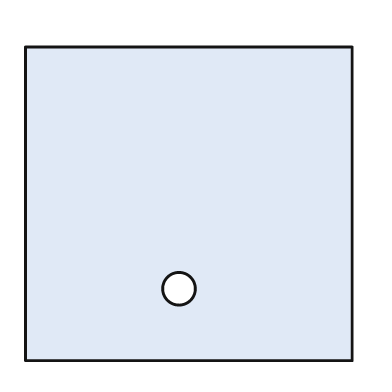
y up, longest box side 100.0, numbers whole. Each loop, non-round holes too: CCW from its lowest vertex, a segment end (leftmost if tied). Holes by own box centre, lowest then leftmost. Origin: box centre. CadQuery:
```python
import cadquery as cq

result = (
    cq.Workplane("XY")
    .moveTo(-50.0, -48.0)
    .lineTo(50.0, -48.0)
    .lineTo(50.0, 48.0)
    .lineTo(-50.0, 48.0)
    .close()
    .moveTo(-3.0, -26.0)
    .circle(5.0)
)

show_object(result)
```